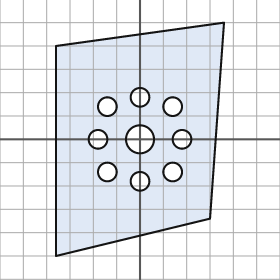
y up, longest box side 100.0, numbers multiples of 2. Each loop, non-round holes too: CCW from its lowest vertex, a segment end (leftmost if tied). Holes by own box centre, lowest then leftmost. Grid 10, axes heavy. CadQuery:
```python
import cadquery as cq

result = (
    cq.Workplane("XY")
    .moveTo(-36.0, -50.0)
    .lineTo(30.0, -34.0)
    .lineTo(36.0, 50.0)
    .lineTo(-36.0, 40.0)
    .close()
    .moveTo(0.0, -18.0)
    .circle(4.0)
    .moveTo(-14.0, -14.0)
    .circle(4.0)
    .moveTo(14.0, -14.0)
    .circle(4.0)
    .moveTo(-18.0, 0.0)
    .circle(4.0)
    .moveTo(0.0, 0.0)
    .circle(6.0)
    .moveTo(18.0, 0.0)
    .circle(4.0)
    .moveTo(-14.0, 14.0)
    .circle(4.0)
    .moveTo(14.0, 14.0)
    .circle(4.0)
    .moveTo(0.0, 18.0)
    .circle(4.0)
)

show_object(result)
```